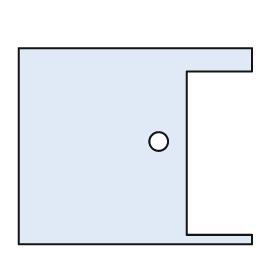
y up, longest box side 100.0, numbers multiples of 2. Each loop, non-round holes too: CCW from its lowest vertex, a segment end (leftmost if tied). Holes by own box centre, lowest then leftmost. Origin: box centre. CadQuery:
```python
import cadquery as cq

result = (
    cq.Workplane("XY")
    .moveTo(-50.0, -42.0)
    .lineTo(50.0, -42.0)
    .lineTo(50.0, -38.0)
    .lineTo(22.0, -38.0)
    .lineTo(22.0, 32.0)
    .lineTo(50.0, 32.0)
    .lineTo(50.0, 42.0)
    .lineTo(-50.0, 42.0)
    .close()
    .moveTo(10.0, 2.0)
    .circle(4.0)
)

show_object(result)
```